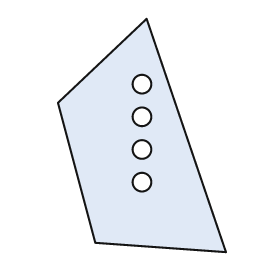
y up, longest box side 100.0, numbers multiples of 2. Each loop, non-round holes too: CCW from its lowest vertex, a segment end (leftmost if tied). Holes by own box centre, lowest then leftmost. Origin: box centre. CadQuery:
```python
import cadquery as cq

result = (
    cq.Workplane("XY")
    .moveTo(36.0, -50.0)
    .lineTo(2.0, 50.0)
    .lineTo(-36.0, 14.0)
    .lineTo(-20.0, -46.0)
    .close()
    .moveTo(0.0, -20.0)
    .circle(4.0)
    .moveTo(0.0, -6.0)
    .circle(4.0)
    .moveTo(0.0, 8.0)
    .circle(4.0)
    .moveTo(0.0, 22.0)
    .circle(4.0)
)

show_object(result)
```